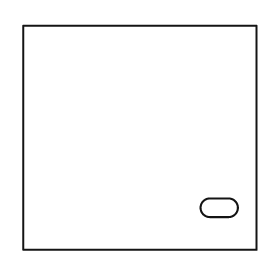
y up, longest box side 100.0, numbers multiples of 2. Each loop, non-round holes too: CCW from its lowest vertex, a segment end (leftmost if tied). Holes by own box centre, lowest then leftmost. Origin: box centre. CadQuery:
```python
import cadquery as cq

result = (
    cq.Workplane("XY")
    .moveTo(-50.0, -48.0)
    .lineTo(50.0, -48.0)
    .lineTo(50.0, 48.0)
    .lineTo(-50.0, 48.0)
    .close()
    .moveTo(30.0, -34.0)
    .lineTo(38.0, -34.0)
    .threePointArc((42.0, -30.0), (38.0, -26.0))
    .lineTo(30.0, -26.0)
    .threePointArc((26.0, -30.0), (30.0, -34.0))
    .close()
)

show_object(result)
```